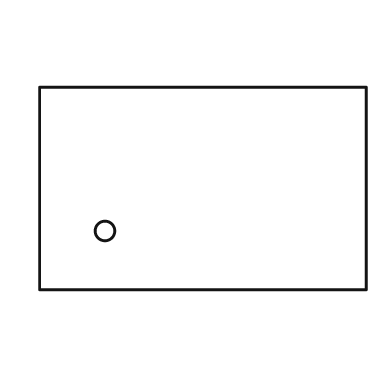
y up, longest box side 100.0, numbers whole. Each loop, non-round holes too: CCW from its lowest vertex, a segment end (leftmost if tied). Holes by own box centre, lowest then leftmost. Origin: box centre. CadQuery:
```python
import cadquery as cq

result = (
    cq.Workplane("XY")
    .moveTo(-50.0, -31.0)
    .lineTo(50.0, -31.0)
    .lineTo(50.0, 31.0)
    .lineTo(-50.0, 31.0)
    .close()
    .moveTo(-30.0, -13.0)
    .circle(3.0)
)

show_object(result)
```